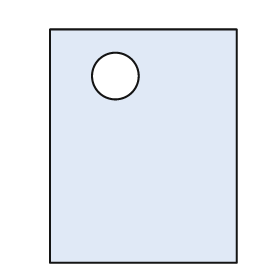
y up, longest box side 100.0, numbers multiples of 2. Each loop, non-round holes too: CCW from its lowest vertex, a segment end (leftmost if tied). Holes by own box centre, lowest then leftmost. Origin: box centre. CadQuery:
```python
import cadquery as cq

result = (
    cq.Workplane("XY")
    .moveTo(-40.0, -50.0)
    .lineTo(40.0, -50.0)
    .lineTo(40.0, 50.0)
    .lineTo(-40.0, 50.0)
    .close()
    .moveTo(-12.0, 30.0)
    .circle(10.0)
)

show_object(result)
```